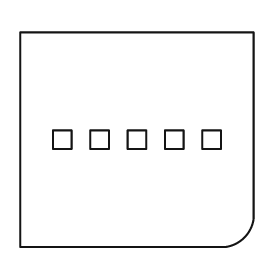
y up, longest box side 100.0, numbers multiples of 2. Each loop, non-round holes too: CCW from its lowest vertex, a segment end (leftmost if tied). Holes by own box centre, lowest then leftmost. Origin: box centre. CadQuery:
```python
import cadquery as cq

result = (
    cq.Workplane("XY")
    .moveTo(-50.0, -46.0)
    .lineTo(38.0, -46.0)
    .threePointArc((46.0, -42.0), (50.0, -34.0))
    .lineTo(50.0, 46.0)
    .lineTo(-50.0, 46.0)
    .close()
    .moveTo(-36.0, -4.0)
    .lineTo(-28.0, -4.0)
    .lineTo(-28.0, 4.0)
    .lineTo(-36.0, 4.0)
    .close()
    .moveTo(-20.0, -4.0)
    .lineTo(-12.0, -4.0)
    .lineTo(-12.0, 4.0)
    .lineTo(-20.0, 4.0)
    .close()
    .moveTo(-4.0, -4.0)
    .lineTo(4.0, -4.0)
    .lineTo(4.0, 4.0)
    .lineTo(-4.0, 4.0)
    .close()
    .moveTo(12.0, -4.0)
    .lineTo(20.0, -4.0)
    .lineTo(20.0, 4.0)
    .lineTo(12.0, 4.0)
    .close()
    .moveTo(28.0, -4.0)
    .lineTo(36.0, -4.0)
    .lineTo(36.0, 4.0)
    .lineTo(28.0, 4.0)
    .close()
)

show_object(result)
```